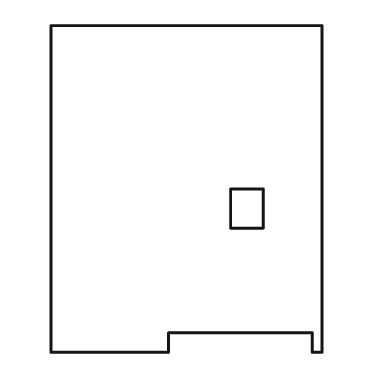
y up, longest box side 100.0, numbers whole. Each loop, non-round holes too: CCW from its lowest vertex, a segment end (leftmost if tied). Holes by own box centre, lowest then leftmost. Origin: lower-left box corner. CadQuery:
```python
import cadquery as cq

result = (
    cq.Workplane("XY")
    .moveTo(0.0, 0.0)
    .lineTo(36.0, 0.0)
    .lineTo(36.0, 6.0)
    .lineTo(80.0, 6.0)
    .lineTo(80.0, 0.0)
    .lineTo(83.0, 0.0)
    .lineTo(83.0, 100.0)
    .lineTo(0.0, 100.0)
    .close()
    .moveTo(55.0, 38.0)
    .lineTo(65.0, 38.0)
    .lineTo(65.0, 50.0)
    .lineTo(55.0, 50.0)
    .close()
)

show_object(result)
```